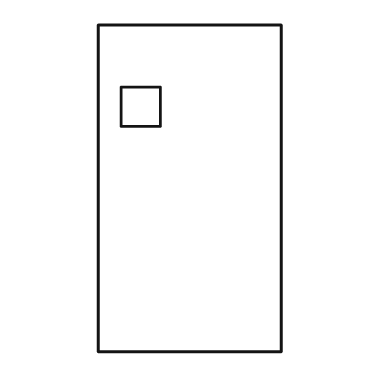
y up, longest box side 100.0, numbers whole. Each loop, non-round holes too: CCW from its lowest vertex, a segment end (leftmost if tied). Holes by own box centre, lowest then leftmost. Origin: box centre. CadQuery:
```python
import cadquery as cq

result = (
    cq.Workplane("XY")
    .moveTo(-28.0, -50.0)
    .lineTo(28.0, -50.0)
    .lineTo(28.0, 50.0)
    .lineTo(-28.0, 50.0)
    .close()
    .moveTo(-21.0, 19.0)
    .lineTo(-9.0, 19.0)
    .lineTo(-9.0, 31.0)
    .lineTo(-21.0, 31.0)
    .close()
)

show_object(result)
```